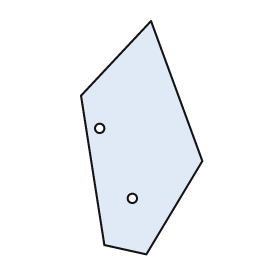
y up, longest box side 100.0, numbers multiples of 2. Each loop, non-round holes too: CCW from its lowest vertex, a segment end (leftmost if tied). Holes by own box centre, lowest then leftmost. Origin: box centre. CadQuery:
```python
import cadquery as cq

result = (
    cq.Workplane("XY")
    .moveTo(2.0, -50.0)
    .lineTo(26.0, -10.0)
    .lineTo(4.0, 50.0)
    .lineTo(-26.0, 18.0)
    .lineTo(-16.0, -46.0)
    .close()
    .moveTo(-4.0, -26.0)
    .circle(2.0)
    .moveTo(-18.0, 4.0)
    .circle(2.0)
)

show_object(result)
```